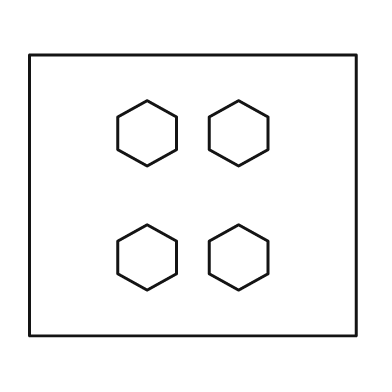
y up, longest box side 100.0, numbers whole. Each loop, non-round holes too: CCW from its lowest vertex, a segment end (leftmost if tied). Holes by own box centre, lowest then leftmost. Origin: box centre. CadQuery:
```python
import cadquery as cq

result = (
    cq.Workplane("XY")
    .moveTo(-50.0, -43.0)
    .lineTo(50.0, -43.0)
    .lineTo(50.0, 43.0)
    .lineTo(-50.0, 43.0)
    .close()
    .moveTo(-14.0, -29.0)
    .lineTo(-5.0, -24.0)
    .lineTo(-5.0, -14.0)
    .lineTo(-14.0, -9.0)
    .lineTo(-23.0, -14.0)
    .lineTo(-23.0, -24.0)
    .close()
    .moveTo(14.0, -29.0)
    .lineTo(23.0, -24.0)
    .lineTo(23.0, -14.0)
    .lineTo(14.0, -9.0)
    .lineTo(5.0, -14.0)
    .lineTo(5.0, -24.0)
    .close()
    .moveTo(-14.0, 9.0)
    .lineTo(-5.0, 14.0)
    .lineTo(-5.0, 24.0)
    .lineTo(-14.0, 29.0)
    .lineTo(-23.0, 24.0)
    .lineTo(-23.0, 14.0)
    .close()
    .moveTo(14.0, 9.0)
    .lineTo(23.0, 14.0)
    .lineTo(23.0, 24.0)
    .lineTo(14.0, 29.0)
    .lineTo(5.0, 24.0)
    .lineTo(5.0, 14.0)
    .close()
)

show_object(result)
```